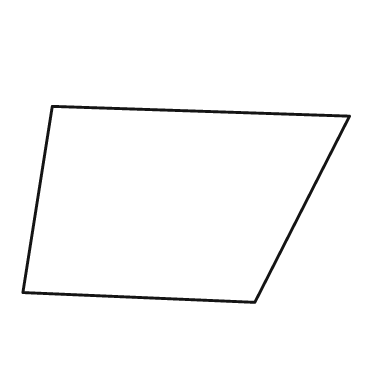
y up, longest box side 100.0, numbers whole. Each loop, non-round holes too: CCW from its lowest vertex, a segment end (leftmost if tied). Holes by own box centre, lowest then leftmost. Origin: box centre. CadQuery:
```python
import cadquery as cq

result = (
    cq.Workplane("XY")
    .moveTo(21.0, -30.0)
    .lineTo(50.0, 27.0)
    .lineTo(-41.0, 30.0)
    .lineTo(-50.0, -27.0)
    .close()
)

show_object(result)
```